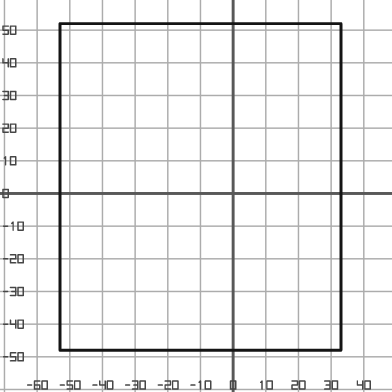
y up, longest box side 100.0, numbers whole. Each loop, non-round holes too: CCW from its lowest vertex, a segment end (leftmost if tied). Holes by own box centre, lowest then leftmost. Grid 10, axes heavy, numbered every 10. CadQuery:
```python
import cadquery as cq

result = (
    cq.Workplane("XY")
    .moveTo(-53.0, -48.0)
    .lineTo(33.0, -48.0)
    .lineTo(33.0, 52.0)
    .lineTo(-53.0, 52.0)
    .close()
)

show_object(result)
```